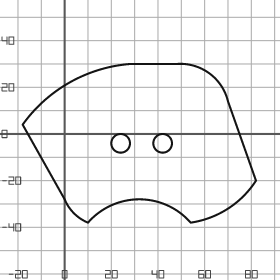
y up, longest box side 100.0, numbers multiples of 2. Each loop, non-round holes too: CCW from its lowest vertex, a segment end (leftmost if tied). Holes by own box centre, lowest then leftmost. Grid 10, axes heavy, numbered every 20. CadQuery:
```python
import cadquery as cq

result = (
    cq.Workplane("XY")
    .moveTo(10.0, -38.0)
    .threePointArc((32.0, -28.0), (54.0, -38.0))
    .threePointArc((70.0, -32.0), (82.0, -20.0))
    .lineTo(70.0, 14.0)
    .threePointArc((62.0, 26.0), (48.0, 30.0))
    .lineTo(28.0, 30.0)
    .threePointArc((2.0, 22.0), (-18.0, 4.0))
    .lineTo(0.0, -28.0)
    .threePointArc((4.0, -34.0), (10.0, -38.0))
    .close()
    .moveTo(24.0, -4.0)
    .circle(4.0)
    .moveTo(42.0, -4.0)
    .circle(4.0)
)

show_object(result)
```